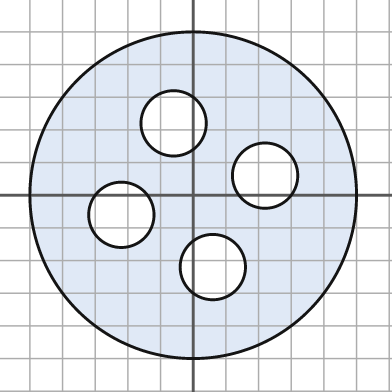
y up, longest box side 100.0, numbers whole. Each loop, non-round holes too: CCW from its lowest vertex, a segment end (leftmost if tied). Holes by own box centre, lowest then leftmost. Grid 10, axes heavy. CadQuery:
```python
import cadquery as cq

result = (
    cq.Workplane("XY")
    .moveTo(0.0, 0.0)
    .circle(50.0)
    .moveTo(6.0, -22.0)
    .circle(10.0)
    .moveTo(-22.0, -6.0)
    .circle(10.0)
    .moveTo(22.0, 6.0)
    .circle(10.0)
    .moveTo(-6.0, 22.0)
    .circle(10.0)
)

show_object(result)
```